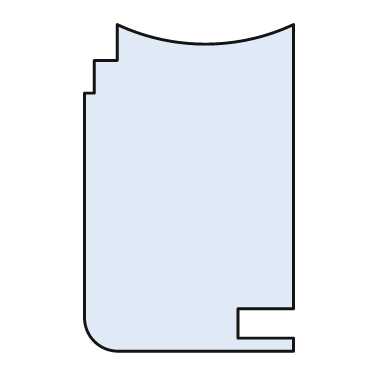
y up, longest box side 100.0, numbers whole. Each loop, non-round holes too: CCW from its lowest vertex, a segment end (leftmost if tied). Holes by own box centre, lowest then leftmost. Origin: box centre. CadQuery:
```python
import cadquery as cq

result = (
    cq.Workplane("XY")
    .moveTo(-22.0, -50.0)
    .lineTo(32.0, -50.0)
    .lineTo(32.0, -46.0)
    .lineTo(15.0, -46.0)
    .lineTo(15.0, -37.0)
    .lineTo(32.0, -37.0)
    .lineTo(32.0, 50.0)
    .threePointArc((5.0, 44.0), (-22.0, 50.0))
    .lineTo(-22.0, 39.0)
    .lineTo(-29.0, 39.0)
    .lineTo(-29.0, 29.0)
    .lineTo(-32.0, 29.0)
    .lineTo(-32.0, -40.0)
    .threePointArc((-29.0, -47.0), (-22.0, -50.0))
    .close()
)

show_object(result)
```